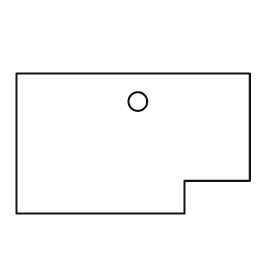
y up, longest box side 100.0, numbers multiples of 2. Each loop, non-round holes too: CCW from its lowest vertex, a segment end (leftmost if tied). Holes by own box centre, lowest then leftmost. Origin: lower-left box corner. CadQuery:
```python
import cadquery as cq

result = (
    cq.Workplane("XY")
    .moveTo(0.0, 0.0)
    .lineTo(72.0, 0.0)
    .lineTo(72.0, 14.0)
    .lineTo(100.0, 14.0)
    .lineTo(100.0, 60.0)
    .lineTo(0.0, 60.0)
    .close()
    .moveTo(52.0, 48.0)
    .circle(4.0)
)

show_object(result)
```